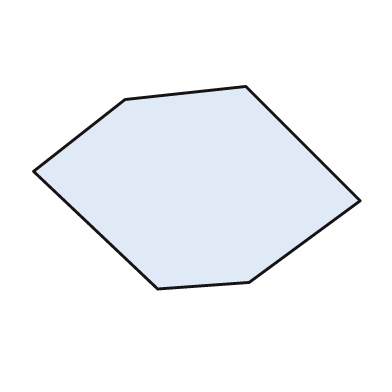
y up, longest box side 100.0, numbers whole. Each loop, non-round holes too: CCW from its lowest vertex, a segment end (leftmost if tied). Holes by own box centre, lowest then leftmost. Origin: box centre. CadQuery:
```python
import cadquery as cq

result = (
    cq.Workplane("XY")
    .moveTo(-12.0, -31.0)
    .lineTo(16.0, -29.0)
    .lineTo(50.0, -4.0)
    .lineTo(15.0, 31.0)
    .lineTo(-22.0, 27.0)
    .lineTo(-50.0, 5.0)
    .close()
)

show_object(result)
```